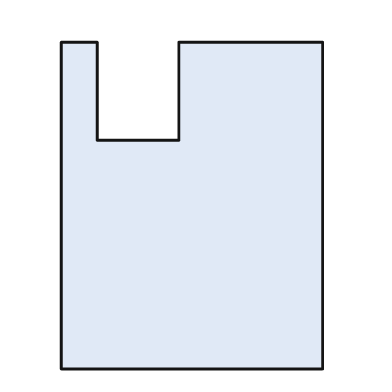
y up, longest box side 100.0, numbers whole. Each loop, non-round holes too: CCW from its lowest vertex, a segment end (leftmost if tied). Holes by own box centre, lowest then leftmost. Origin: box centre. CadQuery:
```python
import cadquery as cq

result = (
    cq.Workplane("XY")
    .moveTo(-40.0, -50.0)
    .lineTo(40.0, -50.0)
    .lineTo(40.0, 50.0)
    .lineTo(-4.0, 50.0)
    .lineTo(-4.0, 20.0)
    .lineTo(-29.0, 20.0)
    .lineTo(-29.0, 50.0)
    .lineTo(-40.0, 50.0)
    .close()
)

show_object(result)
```